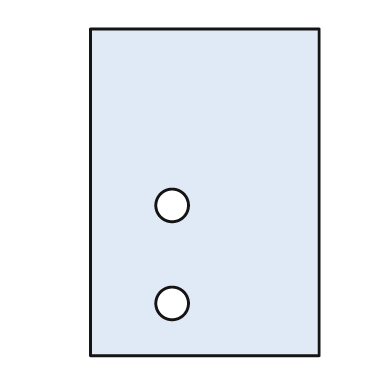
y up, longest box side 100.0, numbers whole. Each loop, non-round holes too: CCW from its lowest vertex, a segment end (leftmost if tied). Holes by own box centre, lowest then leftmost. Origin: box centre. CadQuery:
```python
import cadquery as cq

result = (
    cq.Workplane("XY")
    .moveTo(-35.0, -50.0)
    .lineTo(35.0, -50.0)
    .lineTo(35.0, 50.0)
    .lineTo(-35.0, 50.0)
    .close()
    .moveTo(-10.0, -34.0)
    .circle(5.0)
    .moveTo(-10.0, -4.0)
    .circle(5.0)
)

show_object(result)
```